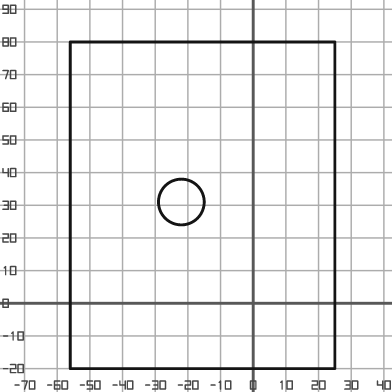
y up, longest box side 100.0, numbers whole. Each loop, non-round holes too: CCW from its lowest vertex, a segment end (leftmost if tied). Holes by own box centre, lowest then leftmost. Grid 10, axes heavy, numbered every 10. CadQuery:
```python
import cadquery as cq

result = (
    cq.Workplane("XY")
    .moveTo(-56.0, -20.0)
    .lineTo(25.0, -20.0)
    .lineTo(25.0, 80.0)
    .lineTo(-56.0, 80.0)
    .close()
    .moveTo(-22.0, 31.0)
    .circle(7.0)
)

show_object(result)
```